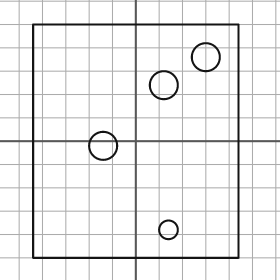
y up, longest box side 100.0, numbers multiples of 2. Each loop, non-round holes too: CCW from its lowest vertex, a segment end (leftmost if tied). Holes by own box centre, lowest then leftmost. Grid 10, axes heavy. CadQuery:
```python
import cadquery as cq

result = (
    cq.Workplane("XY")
    .moveTo(-44.0, -50.0)
    .lineTo(44.0, -50.0)
    .lineTo(44.0, 50.0)
    .lineTo(-44.0, 50.0)
    .close()
    .moveTo(14.0, -38.0)
    .circle(4.0)
    .moveTo(-14.0, -2.0)
    .circle(6.0)
    .moveTo(12.0, 24.0)
    .circle(6.0)
    .moveTo(30.0, 36.0)
    .circle(6.0)
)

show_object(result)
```